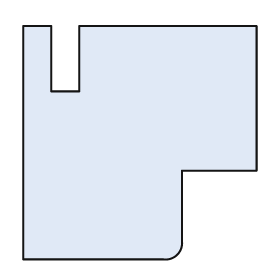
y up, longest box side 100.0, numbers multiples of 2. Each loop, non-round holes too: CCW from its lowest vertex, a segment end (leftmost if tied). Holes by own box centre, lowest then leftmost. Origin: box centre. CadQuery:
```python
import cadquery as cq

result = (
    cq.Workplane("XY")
    .moveTo(-50.0, -50.0)
    .lineTo(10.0, -50.0)
    .threePointArc((16.0, -48.0), (18.0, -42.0))
    .lineTo(18.0, -12.0)
    .lineTo(50.0, -12.0)
    .lineTo(50.0, 50.0)
    .lineTo(-26.0, 50.0)
    .lineTo(-26.0, 22.0)
    .lineTo(-38.0, 22.0)
    .lineTo(-38.0, 50.0)
    .lineTo(-50.0, 50.0)
    .close()
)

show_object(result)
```